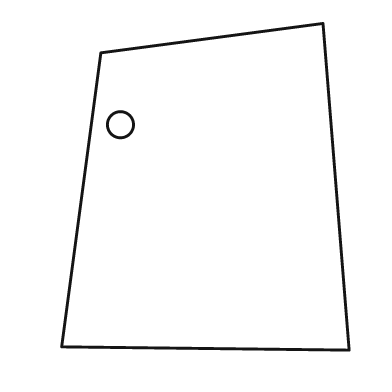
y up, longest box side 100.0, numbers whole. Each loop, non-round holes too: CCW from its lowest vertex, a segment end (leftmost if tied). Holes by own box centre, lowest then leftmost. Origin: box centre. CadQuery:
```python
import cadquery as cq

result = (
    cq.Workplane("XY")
    .moveTo(44.0, -50.0)
    .lineTo(36.0, 50.0)
    .lineTo(-32.0, 41.0)
    .lineTo(-44.0, -49.0)
    .close()
    .moveTo(-26.0, 19.0)
    .circle(4.0)
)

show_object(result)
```